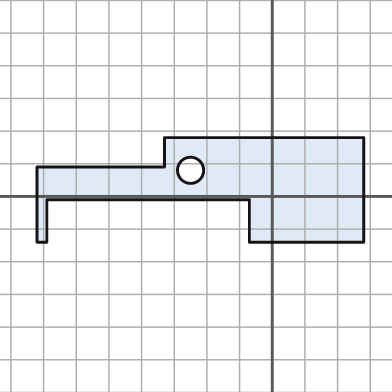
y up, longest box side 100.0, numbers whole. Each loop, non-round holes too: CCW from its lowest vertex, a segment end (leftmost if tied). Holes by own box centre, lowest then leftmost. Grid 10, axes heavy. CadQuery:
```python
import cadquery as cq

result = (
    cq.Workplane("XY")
    .moveTo(-72.0, -14.0)
    .lineTo(-69.0, -14.0)
    .lineTo(-69.0, -1.0)
    .lineTo(-7.0, -1.0)
    .lineTo(-7.0, -14.0)
    .lineTo(28.0, -14.0)
    .lineTo(28.0, 18.0)
    .lineTo(-33.0, 18.0)
    .lineTo(-33.0, 9.0)
    .lineTo(-72.0, 9.0)
    .close()
    .moveTo(-25.0, 8.0)
    .circle(4.0)
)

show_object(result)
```